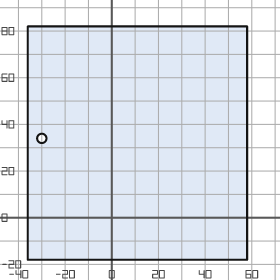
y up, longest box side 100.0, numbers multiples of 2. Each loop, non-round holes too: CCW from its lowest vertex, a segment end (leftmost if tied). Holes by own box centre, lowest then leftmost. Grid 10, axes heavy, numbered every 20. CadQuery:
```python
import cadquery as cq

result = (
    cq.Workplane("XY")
    .moveTo(-36.0, -18.0)
    .lineTo(58.0, -18.0)
    .lineTo(58.0, 82.0)
    .lineTo(-36.0, 82.0)
    .close()
    .moveTo(-30.0, 34.0)
    .circle(2.0)
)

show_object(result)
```